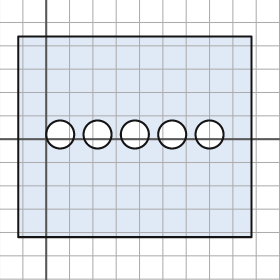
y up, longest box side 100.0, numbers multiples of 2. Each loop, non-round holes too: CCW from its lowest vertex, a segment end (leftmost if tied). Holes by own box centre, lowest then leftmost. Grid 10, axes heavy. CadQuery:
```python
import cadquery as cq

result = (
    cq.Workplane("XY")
    .moveTo(-12.0, -42.0)
    .lineTo(88.0, -42.0)
    .lineTo(88.0, 44.0)
    .lineTo(-12.0, 44.0)
    .close()
    .moveTo(6.0, 2.0)
    .circle(6.0)
    .moveTo(22.0, 2.0)
    .circle(6.0)
    .moveTo(38.0, 2.0)
    .circle(6.0)
    .moveTo(54.0, 2.0)
    .circle(6.0)
    .moveTo(70.0, 2.0)
    .circle(6.0)
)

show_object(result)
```